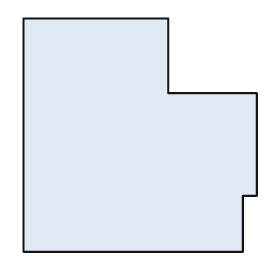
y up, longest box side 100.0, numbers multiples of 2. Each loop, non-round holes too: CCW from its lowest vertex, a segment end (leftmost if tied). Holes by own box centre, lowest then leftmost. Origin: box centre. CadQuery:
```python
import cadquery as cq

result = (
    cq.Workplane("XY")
    .moveTo(-50.0, -50.0)
    .lineTo(44.0, -50.0)
    .lineTo(44.0, -26.0)
    .lineTo(50.0, -26.0)
    .lineTo(50.0, 18.0)
    .lineTo(12.0, 18.0)
    .lineTo(12.0, 50.0)
    .lineTo(-50.0, 50.0)
    .close()
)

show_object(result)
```